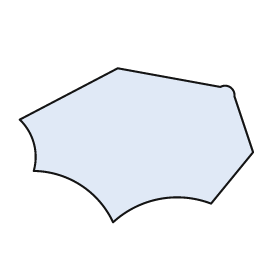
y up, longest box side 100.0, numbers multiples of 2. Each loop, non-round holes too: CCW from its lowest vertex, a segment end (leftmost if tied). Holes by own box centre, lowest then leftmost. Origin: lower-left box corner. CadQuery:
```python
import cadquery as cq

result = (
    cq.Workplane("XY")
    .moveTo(40.0, 0.0)
    .threePointArc((60.0, 10.0), (82.0, 8.0))
    .lineTo(100.0, 30.0)
    .lineTo(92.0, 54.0)
    .threePointArc((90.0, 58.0), (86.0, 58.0))
    .lineTo(42.0, 66.0)
    .lineTo(0.0, 44.0)
    .threePointArc((6.0, 34.0), (6.0, 22.0))
    .threePointArc((26.0, 16.0), (40.0, 0.0))
    .close()
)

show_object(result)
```